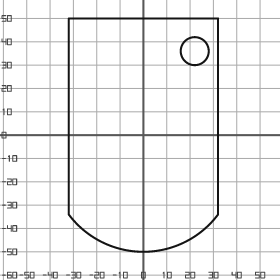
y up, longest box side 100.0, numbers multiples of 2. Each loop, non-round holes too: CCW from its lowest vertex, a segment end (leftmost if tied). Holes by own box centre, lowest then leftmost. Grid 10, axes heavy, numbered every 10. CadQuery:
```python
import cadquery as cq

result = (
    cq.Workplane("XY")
    .moveTo(-32.0, -34.0)
    .threePointArc((0.0, -50.0), (32.0, -34.0))
    .lineTo(32.0, 50.0)
    .lineTo(-32.0, 50.0)
    .close()
    .moveTo(22.0, 36.0)
    .circle(6.0)
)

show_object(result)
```